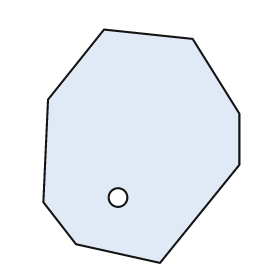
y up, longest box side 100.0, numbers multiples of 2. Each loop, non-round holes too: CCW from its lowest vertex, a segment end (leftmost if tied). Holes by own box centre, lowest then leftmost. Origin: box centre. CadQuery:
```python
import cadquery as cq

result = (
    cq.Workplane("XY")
    .moveTo(8.0, -50.0)
    .lineTo(42.0, -8.0)
    .lineTo(42.0, 14.0)
    .lineTo(22.0, 46.0)
    .lineTo(-16.0, 50.0)
    .lineTo(-40.0, 20.0)
    .lineTo(-42.0, -24.0)
    .lineTo(-28.0, -42.0)
    .close()
    .moveTo(-10.0, -22.0)
    .circle(4.0)
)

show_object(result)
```